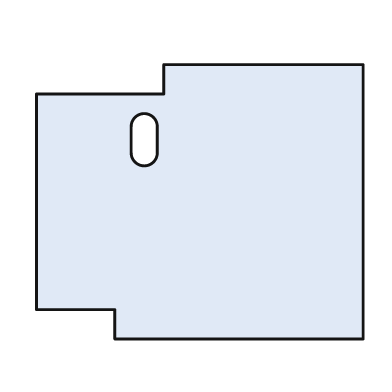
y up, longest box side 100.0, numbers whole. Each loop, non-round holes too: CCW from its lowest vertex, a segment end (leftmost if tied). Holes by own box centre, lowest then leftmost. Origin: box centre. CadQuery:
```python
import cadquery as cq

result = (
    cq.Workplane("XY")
    .moveTo(-26.0, -42.0)
    .lineTo(50.0, -42.0)
    .lineTo(50.0, 42.0)
    .lineTo(-11.0, 42.0)
    .lineTo(-11.0, 33.0)
    .lineTo(-50.0, 33.0)
    .lineTo(-50.0, -33.0)
    .lineTo(-26.0, -33.0)
    .close()
    .moveTo(-21.0, 15.0)
    .threePointArc((-17.0, 11.0), (-13.0, 15.0))
    .lineTo(-13.0, 23.0)
    .threePointArc((-17.0, 27.0), (-21.0, 23.0))
    .close()
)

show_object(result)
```